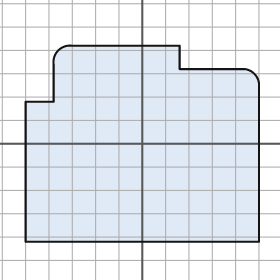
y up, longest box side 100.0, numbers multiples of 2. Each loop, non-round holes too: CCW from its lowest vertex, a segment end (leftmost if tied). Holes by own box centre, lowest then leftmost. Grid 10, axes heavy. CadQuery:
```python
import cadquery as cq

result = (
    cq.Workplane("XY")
    .moveTo(-50.0, -42.0)
    .lineTo(50.0, -42.0)
    .lineTo(50.0, 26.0)
    .threePointArc((48.0, 30.0), (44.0, 32.0))
    .lineTo(16.0, 32.0)
    .lineTo(16.0, 42.0)
    .lineTo(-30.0, 42.0)
    .threePointArc((-36.0, 40.0), (-38.0, 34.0))
    .lineTo(-38.0, 18.0)
    .lineTo(-50.0, 18.0)
    .close()
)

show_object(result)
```